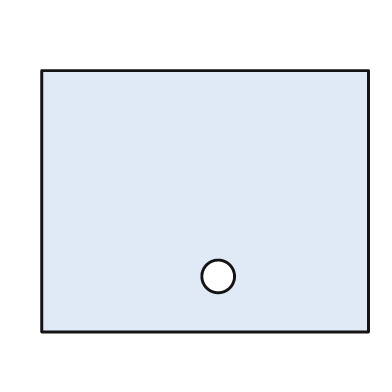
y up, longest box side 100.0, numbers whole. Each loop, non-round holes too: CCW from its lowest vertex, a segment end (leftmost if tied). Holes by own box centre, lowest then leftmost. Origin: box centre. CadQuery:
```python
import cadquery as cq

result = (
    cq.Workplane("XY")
    .moveTo(-50.0, -40.0)
    .lineTo(50.0, -40.0)
    .lineTo(50.0, 40.0)
    .lineTo(-50.0, 40.0)
    .close()
    .moveTo(4.0, -23.0)
    .circle(5.0)
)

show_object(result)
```